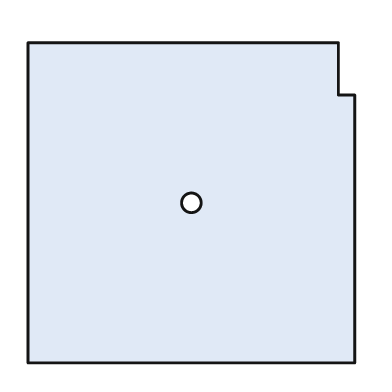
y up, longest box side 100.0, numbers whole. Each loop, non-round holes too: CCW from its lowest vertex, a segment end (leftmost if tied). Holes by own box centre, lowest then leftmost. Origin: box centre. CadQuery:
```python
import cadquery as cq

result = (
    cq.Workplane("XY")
    .moveTo(-50.0, -49.0)
    .lineTo(50.0, -49.0)
    .lineTo(50.0, 33.0)
    .lineTo(45.0, 33.0)
    .lineTo(45.0, 49.0)
    .lineTo(-50.0, 49.0)
    .close()
    .moveTo(0.0, 0.0)
    .circle(3.0)
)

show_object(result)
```